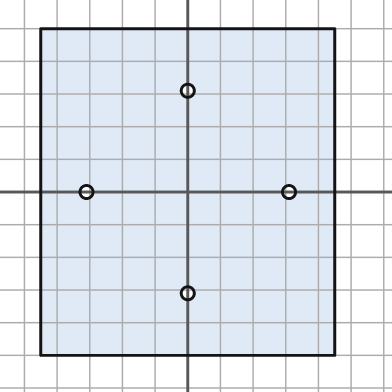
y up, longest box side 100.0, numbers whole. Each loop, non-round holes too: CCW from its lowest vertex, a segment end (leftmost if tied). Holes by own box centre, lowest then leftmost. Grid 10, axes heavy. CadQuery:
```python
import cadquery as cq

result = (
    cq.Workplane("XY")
    .moveTo(-45.0, -50.0)
    .lineTo(45.0, -50.0)
    .lineTo(45.0, 50.0)
    .lineTo(-45.0, 50.0)
    .close()
    .moveTo(0.0, -31.0)
    .circle(2.0)
    .moveTo(-31.0, 0.0)
    .circle(2.0)
    .moveTo(31.0, 0.0)
    .circle(2.0)
    .moveTo(0.0, 31.0)
    .circle(2.0)
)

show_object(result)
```